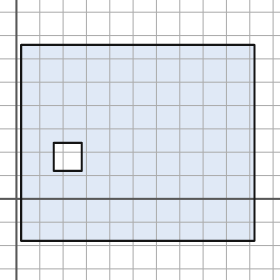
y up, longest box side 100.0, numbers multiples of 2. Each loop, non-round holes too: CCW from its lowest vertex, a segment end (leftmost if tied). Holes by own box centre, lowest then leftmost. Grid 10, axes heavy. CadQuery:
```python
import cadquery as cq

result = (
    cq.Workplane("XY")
    .moveTo(2.0, -18.0)
    .lineTo(102.0, -18.0)
    .lineTo(102.0, 66.0)
    .lineTo(2.0, 66.0)
    .close()
    .moveTo(16.0, 12.0)
    .lineTo(28.0, 12.0)
    .lineTo(28.0, 24.0)
    .lineTo(16.0, 24.0)
    .close()
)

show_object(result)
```